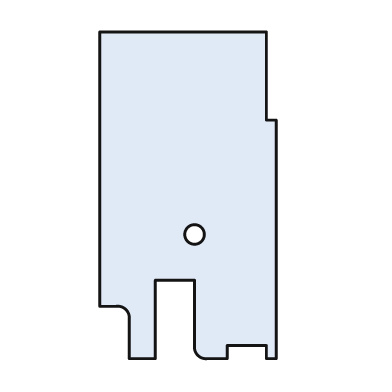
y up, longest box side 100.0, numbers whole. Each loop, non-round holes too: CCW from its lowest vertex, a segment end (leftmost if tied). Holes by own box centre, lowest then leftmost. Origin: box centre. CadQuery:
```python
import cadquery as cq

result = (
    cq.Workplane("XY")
    .moveTo(-18.0, -50.0)
    .lineTo(-10.0, -50.0)
    .lineTo(-10.0, -26.0)
    .lineTo(2.0, -26.0)
    .lineTo(2.0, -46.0)
    .threePointArc((3.0, -49.0), (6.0, -50.0))
    .lineTo(12.0, -50.0)
    .lineTo(12.0, -46.0)
    .lineTo(24.0, -46.0)
    .lineTo(24.0, -50.0)
    .lineTo(27.0, -50.0)
    .lineTo(27.0, 23.0)
    .lineTo(24.0, 23.0)
    .lineTo(24.0, 50.0)
    .lineTo(-27.0, 50.0)
    .lineTo(-27.0, -34.0)
    .lineTo(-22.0, -34.0)
    .threePointArc((-19.0, -35.0), (-18.0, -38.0))
    .close()
    .moveTo(2.0, -12.0)
    .circle(3.0)
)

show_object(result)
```